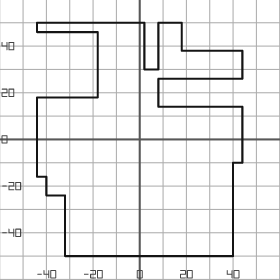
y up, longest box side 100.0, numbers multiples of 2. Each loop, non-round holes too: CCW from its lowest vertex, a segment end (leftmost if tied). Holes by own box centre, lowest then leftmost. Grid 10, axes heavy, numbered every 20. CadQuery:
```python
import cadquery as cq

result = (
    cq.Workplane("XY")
    .moveTo(-32.0, -50.0)
    .lineTo(40.0, -50.0)
    .lineTo(40.0, -10.0)
    .lineTo(44.0, -10.0)
    .lineTo(44.0, 14.0)
    .lineTo(8.0, 14.0)
    .lineTo(8.0, 26.0)
    .lineTo(44.0, 26.0)
    .lineTo(44.0, 38.0)
    .lineTo(18.0, 38.0)
    .lineTo(18.0, 50.0)
    .lineTo(8.0, 50.0)
    .lineTo(8.0, 30.0)
    .lineTo(2.0, 30.0)
    .lineTo(2.0, 50.0)
    .lineTo(-44.0, 50.0)
    .lineTo(-44.0, 46.0)
    .lineTo(-18.0, 46.0)
    .lineTo(-18.0, 18.0)
    .lineTo(-44.0, 18.0)
    .lineTo(-44.0, -16.0)
    .lineTo(-40.0, -16.0)
    .lineTo(-40.0, -24.0)
    .lineTo(-32.0, -24.0)
    .close()
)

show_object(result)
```